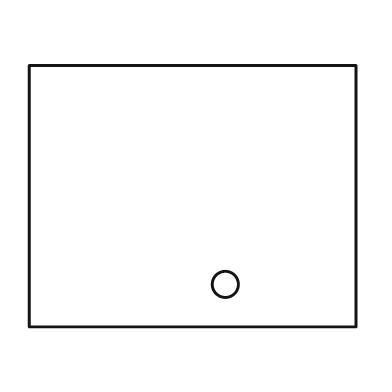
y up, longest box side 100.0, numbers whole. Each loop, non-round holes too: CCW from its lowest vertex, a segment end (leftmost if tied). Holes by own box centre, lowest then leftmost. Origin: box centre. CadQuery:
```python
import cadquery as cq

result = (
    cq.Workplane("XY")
    .moveTo(-50.0, -40.0)
    .lineTo(50.0, -40.0)
    .lineTo(50.0, 40.0)
    .lineTo(-50.0, 40.0)
    .close()
    .moveTo(10.0, -27.0)
    .circle(4.0)
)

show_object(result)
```